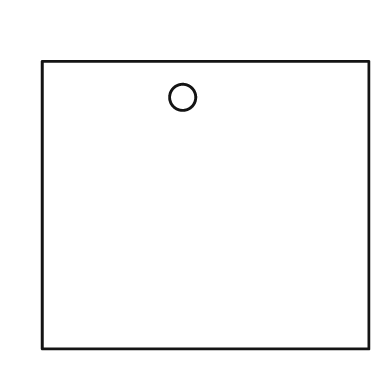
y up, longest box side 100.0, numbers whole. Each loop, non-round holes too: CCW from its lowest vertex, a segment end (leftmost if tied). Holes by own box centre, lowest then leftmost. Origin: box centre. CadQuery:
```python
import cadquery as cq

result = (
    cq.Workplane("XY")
    .moveTo(-50.0, -44.0)
    .lineTo(50.0, -44.0)
    .lineTo(50.0, 44.0)
    .lineTo(-50.0, 44.0)
    .close()
    .moveTo(-7.0, 33.0)
    .circle(4.0)
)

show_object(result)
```